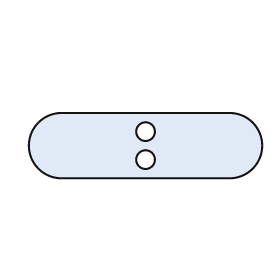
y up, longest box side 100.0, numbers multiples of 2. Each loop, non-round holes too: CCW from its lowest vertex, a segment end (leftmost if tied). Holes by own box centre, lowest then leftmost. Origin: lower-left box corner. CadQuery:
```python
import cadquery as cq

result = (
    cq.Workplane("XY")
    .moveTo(14.0, 0.0)
    .lineTo(86.0, 0.0)
    .threePointArc((100.0, 14.0), (86.0, 28.0))
    .lineTo(14.0, 28.0)
    .threePointArc((0.0, 14.0), (14.0, 0.0))
    .close()
    .moveTo(50.0, 8.0)
    .circle(4.0)
    .moveTo(50.0, 20.0)
    .circle(4.0)
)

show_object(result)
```